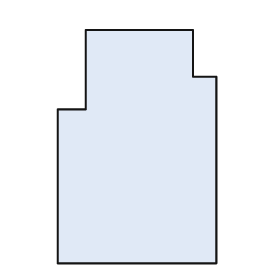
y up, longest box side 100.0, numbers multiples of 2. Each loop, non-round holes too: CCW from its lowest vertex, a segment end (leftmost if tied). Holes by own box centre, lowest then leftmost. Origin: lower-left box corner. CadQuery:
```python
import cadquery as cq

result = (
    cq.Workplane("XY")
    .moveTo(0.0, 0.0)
    .lineTo(68.0, 0.0)
    .lineTo(68.0, 80.0)
    .lineTo(58.0, 80.0)
    .lineTo(58.0, 100.0)
    .lineTo(12.0, 100.0)
    .lineTo(12.0, 66.0)
    .lineTo(0.0, 66.0)
    .close()
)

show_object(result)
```